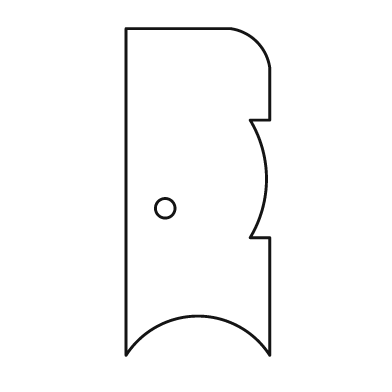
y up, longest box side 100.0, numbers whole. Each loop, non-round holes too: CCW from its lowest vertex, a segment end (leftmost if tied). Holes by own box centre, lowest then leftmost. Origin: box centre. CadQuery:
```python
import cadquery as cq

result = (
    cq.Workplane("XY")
    .moveTo(-22.0, -50.0)
    .threePointArc((0.0, -38.0), (22.0, -50.0))
    .lineTo(22.0, -14.0)
    .lineTo(16.0, -14.0)
    .threePointArc((21.0, 4.0), (16.0, 22.0))
    .lineTo(22.0, 22.0)
    .lineTo(22.0, 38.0)
    .threePointArc((18.0, 46.0), (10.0, 50.0))
    .lineTo(-22.0, 50.0)
    .close()
    .moveTo(-10.0, -5.0)
    .circle(3.0)
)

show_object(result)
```